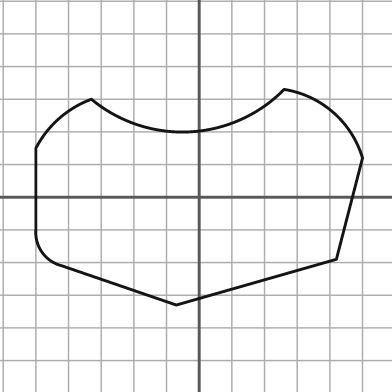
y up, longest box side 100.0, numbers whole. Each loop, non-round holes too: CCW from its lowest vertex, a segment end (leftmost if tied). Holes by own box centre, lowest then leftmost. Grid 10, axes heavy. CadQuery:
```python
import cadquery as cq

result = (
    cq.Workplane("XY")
    .moveTo(-7.0, -33.0)
    .lineTo(42.0, -19.0)
    .lineTo(50.0, 12.0)
    .threePointArc((41.0, 26.0), (26.0, 33.0))
    .threePointArc((-3.0, 20.0), (-33.0, 30.0))
    .threePointArc((-43.0, 24.0), (-50.0, 15.0))
    .lineTo(-50.0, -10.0)
    .threePointArc((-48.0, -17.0), (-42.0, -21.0))
    .close()
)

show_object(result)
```